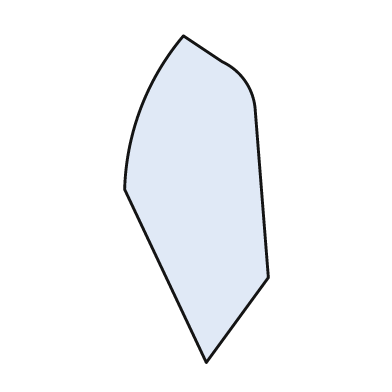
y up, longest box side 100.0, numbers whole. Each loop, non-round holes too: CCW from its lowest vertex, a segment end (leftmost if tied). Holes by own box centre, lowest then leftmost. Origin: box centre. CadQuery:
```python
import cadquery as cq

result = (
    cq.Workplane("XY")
    .moveTo(3.0, -50.0)
    .lineTo(22.0, -24.0)
    .lineTo(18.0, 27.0)
    .threePointArc((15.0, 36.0), (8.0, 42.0))
    .lineTo(-4.0, 50.0)
    .threePointArc((-17.0, 28.0), (-22.0, 3.0))
    .close()
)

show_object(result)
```